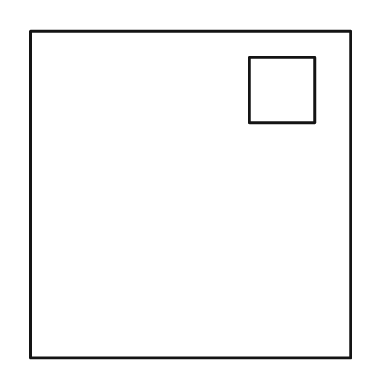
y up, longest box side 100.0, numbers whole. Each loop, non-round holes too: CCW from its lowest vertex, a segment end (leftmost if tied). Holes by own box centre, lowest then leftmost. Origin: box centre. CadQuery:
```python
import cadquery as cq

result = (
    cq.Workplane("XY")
    .moveTo(-49.0, -50.0)
    .lineTo(49.0, -50.0)
    .lineTo(49.0, 50.0)
    .lineTo(-49.0, 50.0)
    .close()
    .moveTo(18.0, 22.0)
    .lineTo(38.0, 22.0)
    .lineTo(38.0, 42.0)
    .lineTo(18.0, 42.0)
    .close()
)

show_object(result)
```